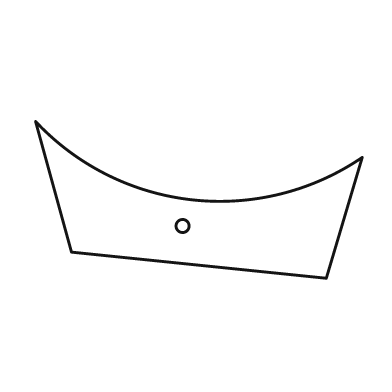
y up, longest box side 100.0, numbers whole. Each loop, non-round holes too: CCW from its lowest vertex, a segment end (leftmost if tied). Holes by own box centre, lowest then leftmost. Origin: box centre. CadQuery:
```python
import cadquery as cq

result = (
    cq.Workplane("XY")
    .moveTo(39.0, -24.0)
    .lineTo(50.0, 13.0)
    .threePointArc((-2.0, 0.0), (-50.0, 24.0))
    .lineTo(-39.0, -16.0)
    .close()
    .moveTo(-5.0, -8.0)
    .circle(2.0)
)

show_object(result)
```